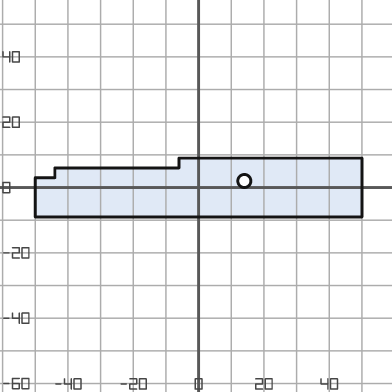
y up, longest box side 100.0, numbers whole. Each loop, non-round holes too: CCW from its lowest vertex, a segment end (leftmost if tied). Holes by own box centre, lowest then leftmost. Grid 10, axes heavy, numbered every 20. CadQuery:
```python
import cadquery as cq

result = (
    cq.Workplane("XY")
    .moveTo(-50.0, -9.0)
    .lineTo(50.0, -9.0)
    .lineTo(50.0, 9.0)
    .lineTo(-6.0, 9.0)
    .lineTo(-6.0, 6.0)
    .lineTo(-44.0, 6.0)
    .lineTo(-44.0, 3.0)
    .lineTo(-50.0, 3.0)
    .close()
    .moveTo(14.0, 2.0)
    .circle(2.0)
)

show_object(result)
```